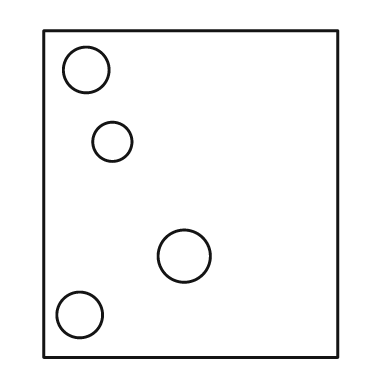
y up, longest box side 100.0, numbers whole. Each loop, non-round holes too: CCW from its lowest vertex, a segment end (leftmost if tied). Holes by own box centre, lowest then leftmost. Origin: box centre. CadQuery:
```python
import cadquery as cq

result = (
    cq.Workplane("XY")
    .moveTo(-45.0, -50.0)
    .lineTo(45.0, -50.0)
    .lineTo(45.0, 50.0)
    .lineTo(-45.0, 50.0)
    .close()
    .moveTo(-34.0, -37.0)
    .circle(7.0)
    .moveTo(-2.0, -19.0)
    .circle(8.0)
    .moveTo(-24.0, 16.0)
    .circle(6.0)
    .moveTo(-32.0, 38.0)
    .circle(7.0)
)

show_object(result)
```